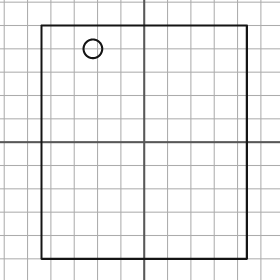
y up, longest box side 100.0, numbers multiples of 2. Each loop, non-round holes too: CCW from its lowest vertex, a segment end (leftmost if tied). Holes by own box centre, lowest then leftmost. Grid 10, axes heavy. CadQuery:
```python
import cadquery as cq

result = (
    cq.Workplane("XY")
    .moveTo(-44.0, -50.0)
    .lineTo(44.0, -50.0)
    .lineTo(44.0, 50.0)
    .lineTo(-44.0, 50.0)
    .close()
    .moveTo(-22.0, 40.0)
    .circle(4.0)
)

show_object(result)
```